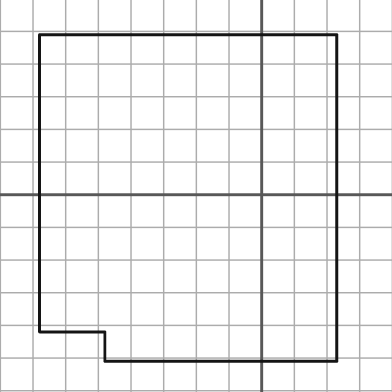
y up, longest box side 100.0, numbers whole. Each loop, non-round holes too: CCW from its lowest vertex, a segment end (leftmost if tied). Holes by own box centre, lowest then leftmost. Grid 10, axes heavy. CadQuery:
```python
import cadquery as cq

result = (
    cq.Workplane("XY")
    .moveTo(-48.0, -51.0)
    .lineTo(23.0, -51.0)
    .lineTo(23.0, 49.0)
    .lineTo(-68.0, 49.0)
    .lineTo(-68.0, -42.0)
    .lineTo(-48.0, -42.0)
    .close()
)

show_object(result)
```